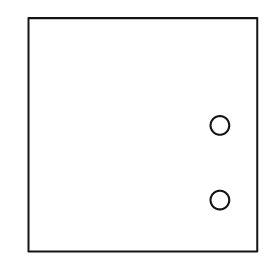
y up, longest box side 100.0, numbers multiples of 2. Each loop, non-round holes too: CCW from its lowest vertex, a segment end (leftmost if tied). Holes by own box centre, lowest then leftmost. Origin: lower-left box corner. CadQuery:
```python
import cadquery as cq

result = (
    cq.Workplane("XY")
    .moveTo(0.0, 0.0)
    .lineTo(98.0, 0.0)
    .lineTo(98.0, 100.0)
    .lineTo(0.0, 100.0)
    .close()
    .moveTo(82.0, 22.0)
    .circle(4.0)
    .moveTo(82.0, 54.0)
    .circle(4.0)
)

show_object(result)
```